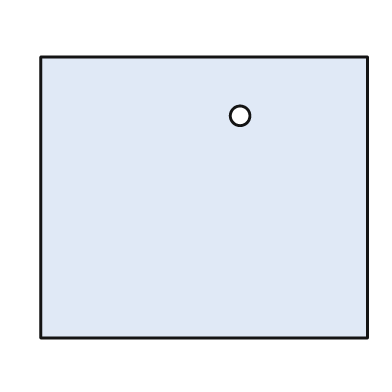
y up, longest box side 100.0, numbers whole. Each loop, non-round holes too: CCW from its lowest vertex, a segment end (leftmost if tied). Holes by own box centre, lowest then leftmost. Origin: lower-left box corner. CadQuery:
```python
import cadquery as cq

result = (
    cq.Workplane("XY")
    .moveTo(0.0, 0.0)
    .lineTo(100.0, 0.0)
    .lineTo(100.0, 86.0)
    .lineTo(0.0, 86.0)
    .close()
    .moveTo(61.0, 68.0)
    .circle(3.0)
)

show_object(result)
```